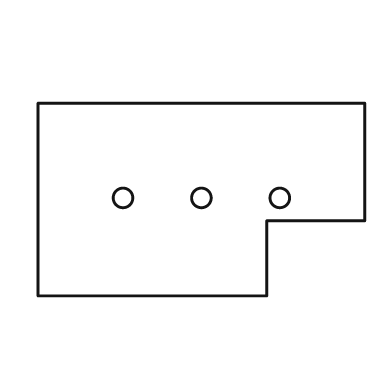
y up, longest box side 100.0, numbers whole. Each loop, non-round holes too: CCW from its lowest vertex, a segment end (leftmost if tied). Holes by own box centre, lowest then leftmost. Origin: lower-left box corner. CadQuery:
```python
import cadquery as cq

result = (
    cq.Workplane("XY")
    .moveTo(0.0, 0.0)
    .lineTo(70.0, 0.0)
    .lineTo(70.0, 23.0)
    .lineTo(100.0, 23.0)
    .lineTo(100.0, 59.0)
    .lineTo(0.0, 59.0)
    .close()
    .moveTo(26.0, 30.0)
    .circle(3.0)
    .moveTo(50.0, 30.0)
    .circle(3.0)
    .moveTo(74.0, 30.0)
    .circle(3.0)
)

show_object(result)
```